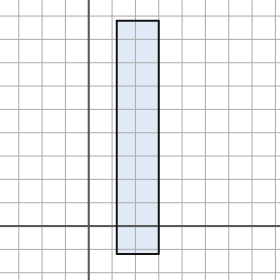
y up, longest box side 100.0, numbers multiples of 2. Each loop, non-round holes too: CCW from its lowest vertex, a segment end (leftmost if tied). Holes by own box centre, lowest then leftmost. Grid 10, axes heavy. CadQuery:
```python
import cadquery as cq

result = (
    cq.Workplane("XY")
    .moveTo(12.0, -12.0)
    .lineTo(30.0, -12.0)
    .lineTo(30.0, 88.0)
    .lineTo(12.0, 88.0)
    .close()
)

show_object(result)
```